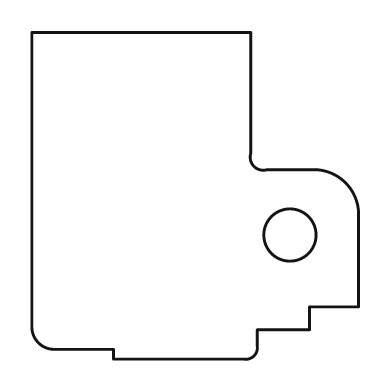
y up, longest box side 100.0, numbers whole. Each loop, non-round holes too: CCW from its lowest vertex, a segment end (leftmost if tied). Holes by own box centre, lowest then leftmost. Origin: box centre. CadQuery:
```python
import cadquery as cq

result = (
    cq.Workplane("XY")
    .moveTo(-25.0, -50.0)
    .lineTo(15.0, -50.0)
    .threePointArc((18.0, -49.0), (19.0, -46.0))
    .lineTo(19.0, -41.0)
    .lineTo(35.0, -41.0)
    .lineTo(35.0, -34.0)
    .lineTo(50.0, -34.0)
    .lineTo(50.0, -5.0)
    .threePointArc((46.0, 4.0), (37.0, 8.0))
    .lineTo(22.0, 8.0)
    .threePointArc((18.0, 9.0), (17.0, 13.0))
    .lineTo(17.0, 50.0)
    .lineTo(-50.0, 50.0)
    .lineTo(-50.0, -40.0)
    .threePointArc((-48.0, -45.0), (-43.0, -47.0))
    .lineTo(-25.0, -47.0)
    .close()
    .moveTo(29.0, -12.0)
    .circle(8.0)
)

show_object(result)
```